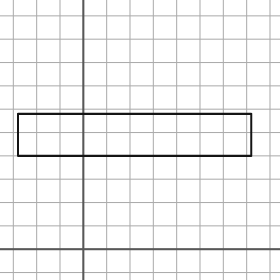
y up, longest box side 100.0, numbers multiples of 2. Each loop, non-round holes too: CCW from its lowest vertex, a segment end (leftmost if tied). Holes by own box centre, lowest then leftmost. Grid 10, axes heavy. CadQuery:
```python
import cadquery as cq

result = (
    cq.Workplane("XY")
    .moveTo(-28.0, 40.0)
    .lineTo(72.0, 40.0)
    .lineTo(72.0, 58.0)
    .lineTo(-28.0, 58.0)
    .close()
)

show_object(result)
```